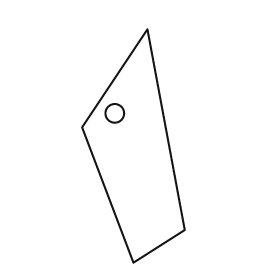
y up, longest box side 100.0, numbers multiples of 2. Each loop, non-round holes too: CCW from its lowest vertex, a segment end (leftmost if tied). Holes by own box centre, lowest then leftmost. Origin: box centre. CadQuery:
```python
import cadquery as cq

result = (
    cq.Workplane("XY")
    .moveTo(0.0, -50.0)
    .lineTo(22.0, -36.0)
    .lineTo(6.0, 50.0)
    .lineTo(-22.0, 8.0)
    .close()
    .moveTo(-8.0, 14.0)
    .circle(4.0)
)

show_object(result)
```